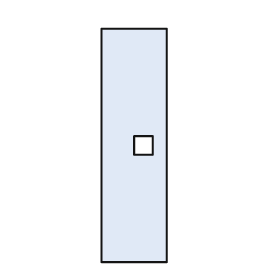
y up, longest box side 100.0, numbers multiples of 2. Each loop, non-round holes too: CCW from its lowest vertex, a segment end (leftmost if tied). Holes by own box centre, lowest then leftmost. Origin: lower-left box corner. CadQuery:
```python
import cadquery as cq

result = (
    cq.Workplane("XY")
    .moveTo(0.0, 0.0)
    .lineTo(28.0, 0.0)
    .lineTo(28.0, 100.0)
    .lineTo(0.0, 100.0)
    .close()
    .moveTo(14.0, 46.0)
    .lineTo(22.0, 46.0)
    .lineTo(22.0, 54.0)
    .lineTo(14.0, 54.0)
    .close()
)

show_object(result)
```